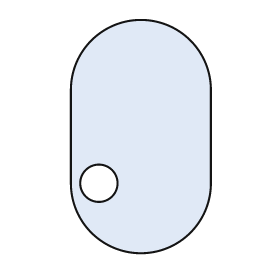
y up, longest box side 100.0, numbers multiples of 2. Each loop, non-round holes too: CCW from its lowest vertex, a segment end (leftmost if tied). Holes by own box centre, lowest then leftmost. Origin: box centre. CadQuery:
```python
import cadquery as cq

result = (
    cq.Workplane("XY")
    .moveTo(-30.0, -20.0)
    .threePointArc((0.0, -50.0), (30.0, -20.0))
    .lineTo(30.0, 20.0)
    .threePointArc((0.0, 50.0), (-30.0, 20.0))
    .close()
    .moveTo(-18.0, -20.0)
    .circle(8.0)
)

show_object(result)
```